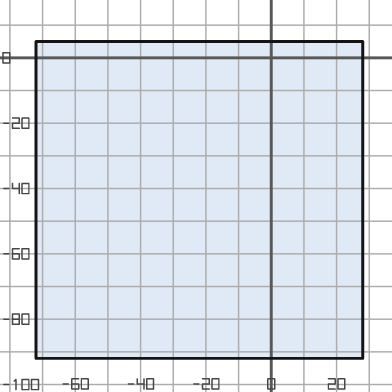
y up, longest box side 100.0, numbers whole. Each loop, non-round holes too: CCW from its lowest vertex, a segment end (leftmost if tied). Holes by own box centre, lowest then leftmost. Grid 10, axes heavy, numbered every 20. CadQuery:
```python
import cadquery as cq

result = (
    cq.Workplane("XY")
    .moveTo(-72.0, -92.0)
    .lineTo(28.0, -92.0)
    .lineTo(28.0, 5.0)
    .lineTo(-72.0, 5.0)
    .close()
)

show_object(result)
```